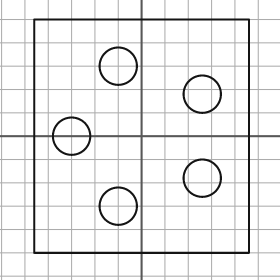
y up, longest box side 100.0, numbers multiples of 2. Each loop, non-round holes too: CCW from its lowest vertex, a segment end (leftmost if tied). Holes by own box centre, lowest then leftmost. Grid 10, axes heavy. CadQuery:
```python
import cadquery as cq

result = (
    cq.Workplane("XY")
    .moveTo(-46.0, -50.0)
    .lineTo(46.0, -50.0)
    .lineTo(46.0, 50.0)
    .lineTo(-46.0, 50.0)
    .close()
    .moveTo(-10.0, -30.0)
    .circle(8.0)
    .moveTo(26.0, -18.0)
    .circle(8.0)
    .moveTo(-30.0, 0.0)
    .circle(8.0)
    .moveTo(26.0, 18.0)
    .circle(8.0)
    .moveTo(-10.0, 30.0)
    .circle(8.0)
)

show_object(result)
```